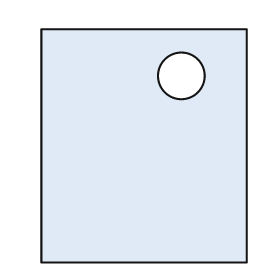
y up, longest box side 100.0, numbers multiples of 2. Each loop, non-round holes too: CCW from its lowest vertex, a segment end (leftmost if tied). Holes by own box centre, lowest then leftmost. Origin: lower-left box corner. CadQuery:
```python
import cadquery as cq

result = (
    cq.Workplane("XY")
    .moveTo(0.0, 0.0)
    .lineTo(88.0, 0.0)
    .lineTo(88.0, 100.0)
    .lineTo(0.0, 100.0)
    .close()
    .moveTo(60.0, 80.0)
    .circle(10.0)
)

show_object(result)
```